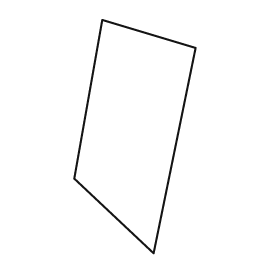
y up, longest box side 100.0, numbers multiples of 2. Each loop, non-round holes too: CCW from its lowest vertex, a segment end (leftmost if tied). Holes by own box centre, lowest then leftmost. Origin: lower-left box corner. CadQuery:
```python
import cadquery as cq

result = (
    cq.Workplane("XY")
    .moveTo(34.0, 0.0)
    .lineTo(52.0, 88.0)
    .lineTo(12.0, 100.0)
    .lineTo(0.0, 32.0)
    .close()
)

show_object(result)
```